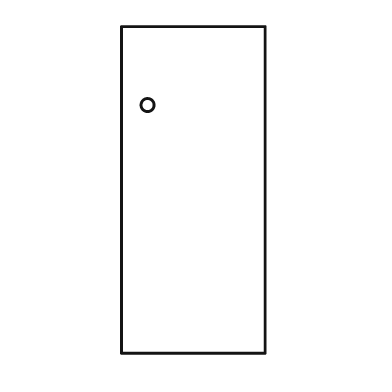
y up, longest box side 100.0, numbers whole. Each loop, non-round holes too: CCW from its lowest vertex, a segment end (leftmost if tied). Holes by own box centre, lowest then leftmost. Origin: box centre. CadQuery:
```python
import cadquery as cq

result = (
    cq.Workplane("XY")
    .moveTo(-22.0, -50.0)
    .lineTo(22.0, -50.0)
    .lineTo(22.0, 50.0)
    .lineTo(-22.0, 50.0)
    .close()
    .moveTo(-14.0, 26.0)
    .circle(2.0)
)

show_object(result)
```